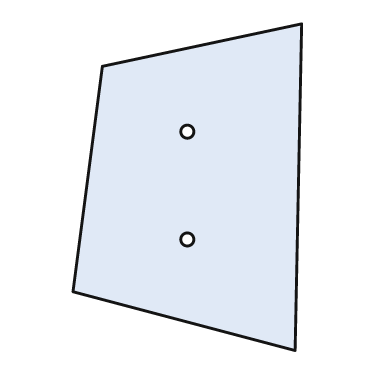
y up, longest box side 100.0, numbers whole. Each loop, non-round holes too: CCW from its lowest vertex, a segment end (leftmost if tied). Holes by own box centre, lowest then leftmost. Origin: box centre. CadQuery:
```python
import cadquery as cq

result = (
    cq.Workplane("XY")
    .moveTo(33.0, -50.0)
    .lineTo(35.0, 50.0)
    .lineTo(-26.0, 37.0)
    .lineTo(-35.0, -32.0)
    .close()
    .moveTo(0.0, -16.0)
    .circle(2.0)
    .moveTo(0.0, 17.0)
    .circle(2.0)
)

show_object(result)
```